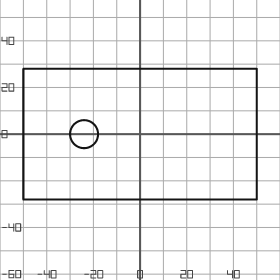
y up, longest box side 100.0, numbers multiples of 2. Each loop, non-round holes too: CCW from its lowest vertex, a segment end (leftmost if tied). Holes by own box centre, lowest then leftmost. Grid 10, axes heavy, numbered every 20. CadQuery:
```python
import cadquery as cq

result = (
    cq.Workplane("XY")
    .moveTo(-50.0, -28.0)
    .lineTo(50.0, -28.0)
    .lineTo(50.0, 28.0)
    .lineTo(-50.0, 28.0)
    .close()
    .moveTo(-24.0, 0.0)
    .circle(6.0)
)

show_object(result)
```